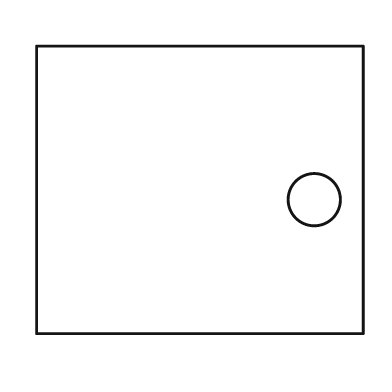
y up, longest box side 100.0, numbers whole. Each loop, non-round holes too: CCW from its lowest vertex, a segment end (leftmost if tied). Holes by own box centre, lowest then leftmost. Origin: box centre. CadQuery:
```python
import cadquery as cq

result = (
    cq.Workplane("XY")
    .moveTo(-50.0, -44.0)
    .lineTo(50.0, -44.0)
    .lineTo(50.0, 44.0)
    .lineTo(-50.0, 44.0)
    .close()
    .moveTo(35.0, -3.0)
    .circle(8.0)
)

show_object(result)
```